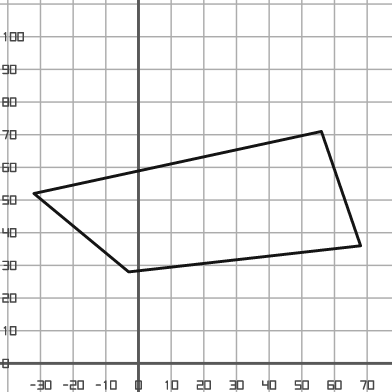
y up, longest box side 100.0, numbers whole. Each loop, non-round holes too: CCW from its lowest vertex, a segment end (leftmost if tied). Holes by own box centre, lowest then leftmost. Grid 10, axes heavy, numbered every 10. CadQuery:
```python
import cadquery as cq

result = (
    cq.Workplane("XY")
    .moveTo(-3.0, 28.0)
    .lineTo(68.0, 36.0)
    .lineTo(56.0, 71.0)
    .lineTo(-32.0, 52.0)
    .close()
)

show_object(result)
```